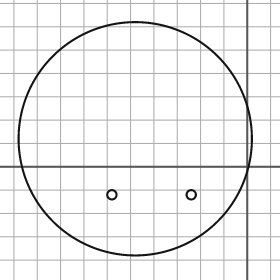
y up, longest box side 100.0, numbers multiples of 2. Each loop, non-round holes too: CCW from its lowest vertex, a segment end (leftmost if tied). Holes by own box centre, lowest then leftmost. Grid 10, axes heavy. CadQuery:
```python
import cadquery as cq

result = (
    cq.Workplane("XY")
    .moveTo(-48.0, 12.0)
    .circle(50.0)
    .moveTo(-58.0, -12.0)
    .circle(2.0)
    .moveTo(-24.0, -12.0)
    .circle(2.0)
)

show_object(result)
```